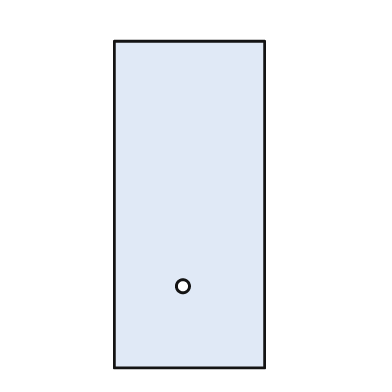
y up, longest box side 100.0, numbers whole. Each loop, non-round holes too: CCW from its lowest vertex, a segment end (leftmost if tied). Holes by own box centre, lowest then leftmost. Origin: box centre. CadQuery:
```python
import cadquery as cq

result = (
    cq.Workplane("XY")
    .moveTo(-23.0, -50.0)
    .lineTo(23.0, -50.0)
    .lineTo(23.0, 50.0)
    .lineTo(-23.0, 50.0)
    .close()
    .moveTo(-2.0, -25.0)
    .circle(2.0)
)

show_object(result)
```